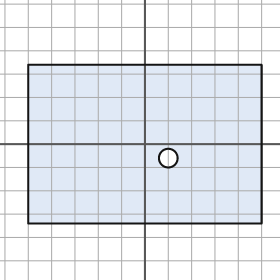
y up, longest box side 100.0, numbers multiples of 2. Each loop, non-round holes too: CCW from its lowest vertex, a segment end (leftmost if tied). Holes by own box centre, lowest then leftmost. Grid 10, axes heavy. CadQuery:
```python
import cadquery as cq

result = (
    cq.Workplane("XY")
    .moveTo(-50.0, -34.0)
    .lineTo(50.0, -34.0)
    .lineTo(50.0, 34.0)
    .lineTo(-50.0, 34.0)
    .close()
    .moveTo(10.0, -6.0)
    .circle(4.0)
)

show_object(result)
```